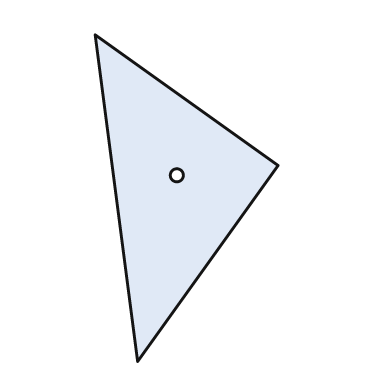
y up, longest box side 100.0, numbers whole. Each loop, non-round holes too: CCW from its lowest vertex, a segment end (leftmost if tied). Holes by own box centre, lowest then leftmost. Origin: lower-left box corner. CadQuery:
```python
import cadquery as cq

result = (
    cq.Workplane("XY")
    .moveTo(13.0, 0.0)
    .lineTo(56.0, 60.0)
    .lineTo(0.0, 100.0)
    .close()
    .moveTo(25.0, 57.0)
    .circle(2.0)
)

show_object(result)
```